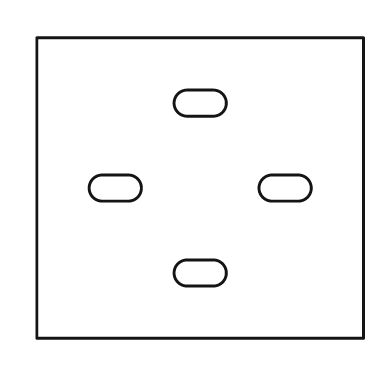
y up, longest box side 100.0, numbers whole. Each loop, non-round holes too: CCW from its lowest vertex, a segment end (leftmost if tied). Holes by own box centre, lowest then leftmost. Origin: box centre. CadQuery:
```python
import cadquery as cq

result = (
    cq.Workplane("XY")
    .moveTo(-50.0, -46.0)
    .lineTo(50.0, -46.0)
    .lineTo(50.0, 46.0)
    .lineTo(-50.0, 46.0)
    .close()
    .moveTo(-4.0, -30.0)
    .lineTo(4.0, -30.0)
    .threePointArc((8.0, -26.0), (4.0, -22.0))
    .lineTo(-4.0, -22.0)
    .threePointArc((-8.0, -26.0), (-4.0, -30.0))
    .close()
    .moveTo(-30.0, -4.0)
    .lineTo(-22.0, -4.0)
    .threePointArc((-18.0, 0.0), (-22.0, 4.0))
    .lineTo(-30.0, 4.0)
    .threePointArc((-34.0, 0.0), (-30.0, -4.0))
    .close()
    .moveTo(22.0, -4.0)
    .lineTo(30.0, -4.0)
    .threePointArc((34.0, 0.0), (30.0, 4.0))
    .lineTo(22.0, 4.0)
    .threePointArc((18.0, 0.0), (22.0, -4.0))
    .close()
    .moveTo(-4.0, 22.0)
    .lineTo(4.0, 22.0)
    .threePointArc((8.0, 26.0), (4.0, 30.0))
    .lineTo(-4.0, 30.0)
    .threePointArc((-8.0, 26.0), (-4.0, 22.0))
    .close()
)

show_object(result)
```